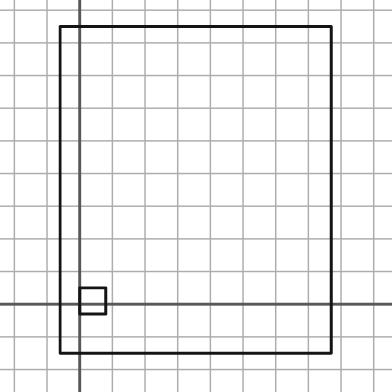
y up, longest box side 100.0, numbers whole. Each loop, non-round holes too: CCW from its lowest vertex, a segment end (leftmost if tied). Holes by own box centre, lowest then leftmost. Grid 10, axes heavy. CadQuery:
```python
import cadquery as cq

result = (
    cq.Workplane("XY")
    .moveTo(-6.0, -15.0)
    .lineTo(77.0, -15.0)
    .lineTo(77.0, 85.0)
    .lineTo(-6.0, 85.0)
    .close()
    .moveTo(0.0, -3.0)
    .lineTo(8.0, -3.0)
    .lineTo(8.0, 5.0)
    .lineTo(0.0, 5.0)
    .close()
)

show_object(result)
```